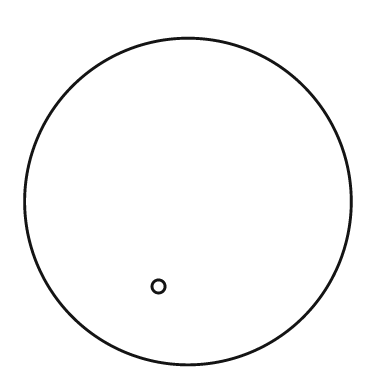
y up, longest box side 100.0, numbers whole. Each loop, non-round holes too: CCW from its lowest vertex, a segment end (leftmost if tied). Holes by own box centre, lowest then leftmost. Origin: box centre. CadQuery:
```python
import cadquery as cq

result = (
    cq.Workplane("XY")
    .moveTo(0.0, 0.0)
    .circle(50.0)
    .moveTo(-9.0, -26.0)
    .circle(2.0)
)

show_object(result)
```